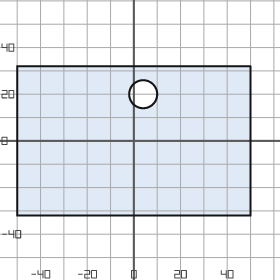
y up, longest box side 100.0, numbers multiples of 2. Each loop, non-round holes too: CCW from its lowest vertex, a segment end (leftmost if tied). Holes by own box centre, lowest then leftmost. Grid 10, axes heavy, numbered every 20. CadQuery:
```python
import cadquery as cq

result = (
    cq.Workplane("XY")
    .moveTo(-50.0, -32.0)
    .lineTo(50.0, -32.0)
    .lineTo(50.0, 32.0)
    .lineTo(-50.0, 32.0)
    .close()
    .moveTo(4.0, 20.0)
    .circle(6.0)
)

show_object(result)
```